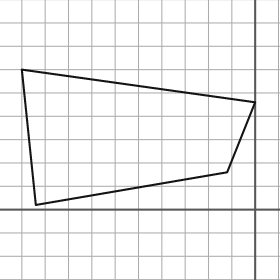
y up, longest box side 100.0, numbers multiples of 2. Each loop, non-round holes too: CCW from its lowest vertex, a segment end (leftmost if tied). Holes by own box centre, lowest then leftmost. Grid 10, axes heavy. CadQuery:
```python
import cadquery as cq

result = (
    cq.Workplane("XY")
    .moveTo(-94.0, 2.0)
    .lineTo(-12.0, 16.0)
    .lineTo(0.0, 46.0)
    .lineTo(-100.0, 60.0)
    .close()
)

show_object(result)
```